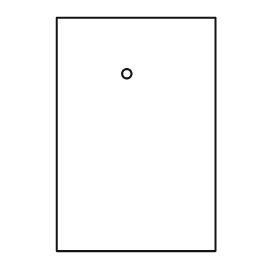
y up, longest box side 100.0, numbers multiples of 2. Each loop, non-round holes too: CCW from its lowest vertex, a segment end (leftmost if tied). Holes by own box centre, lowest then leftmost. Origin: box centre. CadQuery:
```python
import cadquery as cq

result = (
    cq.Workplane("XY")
    .moveTo(-34.0, -50.0)
    .lineTo(34.0, -50.0)
    .lineTo(34.0, 50.0)
    .lineTo(-34.0, 50.0)
    .close()
    .moveTo(-4.0, 26.0)
    .circle(2.0)
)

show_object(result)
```